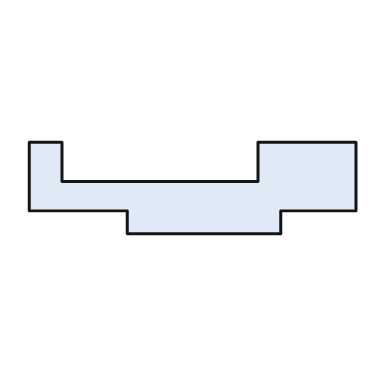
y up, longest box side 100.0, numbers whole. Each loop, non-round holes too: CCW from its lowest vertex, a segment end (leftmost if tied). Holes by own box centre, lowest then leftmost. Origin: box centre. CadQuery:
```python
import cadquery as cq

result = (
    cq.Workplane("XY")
    .moveTo(-20.0, -14.0)
    .lineTo(27.0, -14.0)
    .lineTo(27.0, -7.0)
    .lineTo(50.0, -7.0)
    .lineTo(50.0, 14.0)
    .lineTo(20.0, 14.0)
    .lineTo(20.0, 2.0)
    .lineTo(-40.0, 2.0)
    .lineTo(-40.0, 14.0)
    .lineTo(-50.0, 14.0)
    .lineTo(-50.0, -7.0)
    .lineTo(-20.0, -7.0)
    .close()
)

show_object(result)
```